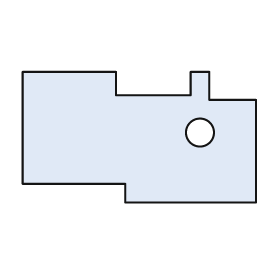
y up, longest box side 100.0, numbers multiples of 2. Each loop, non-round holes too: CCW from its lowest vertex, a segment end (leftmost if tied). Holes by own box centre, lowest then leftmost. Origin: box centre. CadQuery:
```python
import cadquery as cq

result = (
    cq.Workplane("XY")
    .moveTo(-6.0, -28.0)
    .lineTo(50.0, -28.0)
    .lineTo(50.0, 16.0)
    .lineTo(30.0, 16.0)
    .lineTo(30.0, 28.0)
    .lineTo(22.0, 28.0)
    .lineTo(22.0, 18.0)
    .lineTo(-10.0, 18.0)
    .lineTo(-10.0, 28.0)
    .lineTo(-50.0, 28.0)
    .lineTo(-50.0, -20.0)
    .lineTo(-6.0, -20.0)
    .close()
    .moveTo(26.0, 2.0)
    .circle(6.0)
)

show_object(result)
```